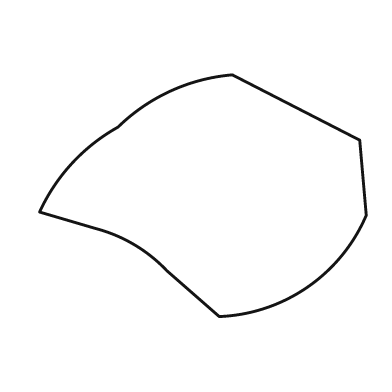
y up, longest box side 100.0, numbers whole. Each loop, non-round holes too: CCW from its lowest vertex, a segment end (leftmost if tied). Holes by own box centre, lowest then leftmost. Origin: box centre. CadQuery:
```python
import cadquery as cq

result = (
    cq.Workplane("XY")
    .moveTo(5.0, -37.0)
    .threePointArc((32.0, -28.0), (50.0, -6.0))
    .lineTo(48.0, 17.0)
    .lineTo(9.0, 37.0)
    .threePointArc((-10.0, 32.0), (-26.0, 21.0))
    .threePointArc((-40.0, 10.0), (-50.0, -5.0))
    .lineTo(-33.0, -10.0)
    .threePointArc((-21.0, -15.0), (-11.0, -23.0))
    .close()
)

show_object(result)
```